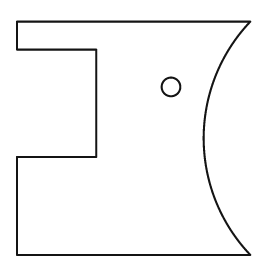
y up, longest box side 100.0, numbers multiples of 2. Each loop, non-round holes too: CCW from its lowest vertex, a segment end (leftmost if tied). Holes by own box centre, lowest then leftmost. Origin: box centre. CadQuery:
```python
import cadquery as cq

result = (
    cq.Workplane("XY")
    .moveTo(-50.0, -50.0)
    .lineTo(50.0, -50.0)
    .threePointArc((30.0, 0.0), (50.0, 50.0))
    .lineTo(-50.0, 50.0)
    .lineTo(-50.0, 38.0)
    .lineTo(-16.0, 38.0)
    .lineTo(-16.0, -8.0)
    .lineTo(-50.0, -8.0)
    .close()
    .moveTo(16.0, 22.0)
    .circle(4.0)
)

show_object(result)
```